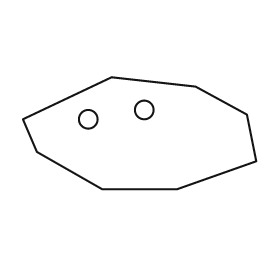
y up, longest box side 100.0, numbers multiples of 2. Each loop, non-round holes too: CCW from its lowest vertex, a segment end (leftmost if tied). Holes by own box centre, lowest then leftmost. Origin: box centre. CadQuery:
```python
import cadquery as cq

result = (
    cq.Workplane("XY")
    .moveTo(-16.0, -24.0)
    .lineTo(16.0, -24.0)
    .lineTo(50.0, -12.0)
    .lineTo(46.0, 8.0)
    .lineTo(24.0, 20.0)
    .lineTo(-12.0, 24.0)
    .lineTo(-50.0, 6.0)
    .lineTo(-44.0, -8.0)
    .close()
    .moveTo(-22.0, 6.0)
    .circle(4.0)
    .moveTo(2.0, 10.0)
    .circle(4.0)
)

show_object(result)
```